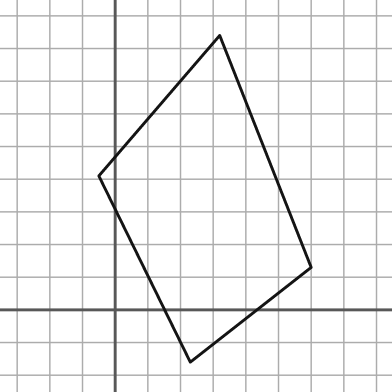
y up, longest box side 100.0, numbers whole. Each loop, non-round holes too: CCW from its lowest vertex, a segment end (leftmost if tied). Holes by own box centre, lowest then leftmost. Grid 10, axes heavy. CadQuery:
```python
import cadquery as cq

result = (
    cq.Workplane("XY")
    .moveTo(23.0, -16.0)
    .lineTo(60.0, 13.0)
    .lineTo(32.0, 84.0)
    .lineTo(-5.0, 41.0)
    .close()
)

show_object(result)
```